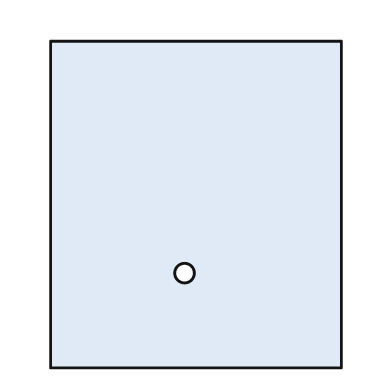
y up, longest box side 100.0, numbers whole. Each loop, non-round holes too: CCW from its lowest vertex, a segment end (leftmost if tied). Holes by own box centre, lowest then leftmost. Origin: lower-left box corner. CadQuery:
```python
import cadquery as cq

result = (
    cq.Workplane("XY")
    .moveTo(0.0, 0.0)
    .lineTo(89.0, 0.0)
    .lineTo(89.0, 100.0)
    .lineTo(0.0, 100.0)
    .close()
    .moveTo(41.0, 29.0)
    .circle(3.0)
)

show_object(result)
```